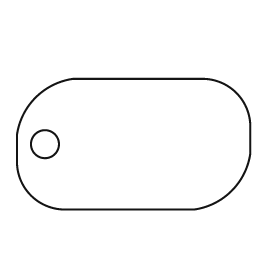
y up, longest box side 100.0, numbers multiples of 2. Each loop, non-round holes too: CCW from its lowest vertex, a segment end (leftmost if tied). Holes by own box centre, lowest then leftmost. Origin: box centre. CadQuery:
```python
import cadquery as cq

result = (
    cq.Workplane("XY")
    .moveTo(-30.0, -28.0)
    .lineTo(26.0, -28.0)
    .threePointArc((42.0, -20.0), (50.0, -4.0))
    .lineTo(50.0, 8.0)
    .threePointArc((44.0, 22.0), (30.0, 28.0))
    .lineTo(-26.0, 28.0)
    .threePointArc((-42.0, 20.0), (-50.0, 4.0))
    .lineTo(-50.0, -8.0)
    .threePointArc((-44.0, -22.0), (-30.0, -28.0))
    .close()
    .moveTo(-38.0, 0.0)
    .circle(6.0)
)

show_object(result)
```